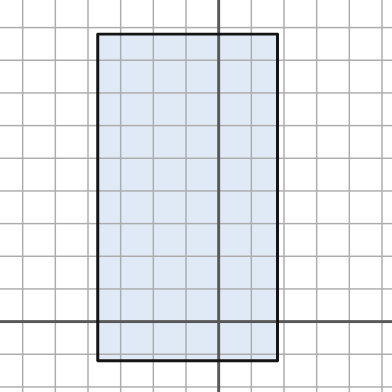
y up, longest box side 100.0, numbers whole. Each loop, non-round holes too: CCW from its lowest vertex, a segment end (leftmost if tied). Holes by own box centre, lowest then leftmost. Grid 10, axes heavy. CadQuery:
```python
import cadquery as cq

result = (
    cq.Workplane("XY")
    .moveTo(-37.0, -12.0)
    .lineTo(18.0, -12.0)
    .lineTo(18.0, 88.0)
    .lineTo(-37.0, 88.0)
    .close()
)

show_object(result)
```